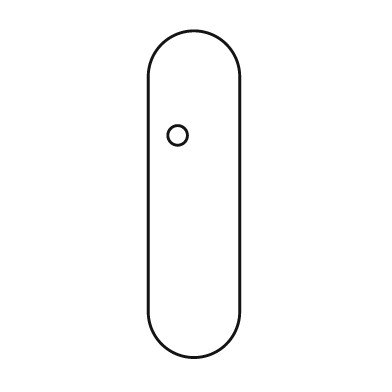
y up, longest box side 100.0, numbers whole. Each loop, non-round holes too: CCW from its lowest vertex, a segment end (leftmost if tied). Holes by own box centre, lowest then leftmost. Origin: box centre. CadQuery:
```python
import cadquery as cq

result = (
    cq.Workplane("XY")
    .moveTo(-14.0, -36.0)
    .threePointArc((0.0, -50.0), (14.0, -36.0))
    .lineTo(14.0, 36.0)
    .threePointArc((0.0, 50.0), (-14.0, 36.0))
    .close()
    .moveTo(-5.0, 18.0)
    .circle(3.0)
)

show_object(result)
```